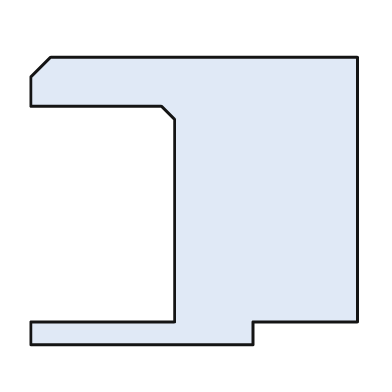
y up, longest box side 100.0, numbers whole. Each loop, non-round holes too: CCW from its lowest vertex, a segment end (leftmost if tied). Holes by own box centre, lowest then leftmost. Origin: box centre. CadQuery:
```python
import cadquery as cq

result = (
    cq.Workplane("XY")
    .moveTo(-50.0, -44.0)
    .lineTo(18.0, -44.0)
    .lineTo(18.0, -37.0)
    .lineTo(50.0, -37.0)
    .lineTo(50.0, 44.0)
    .lineTo(-44.0, 44.0)
    .lineTo(-50.0, 38.0)
    .lineTo(-50.0, 29.0)
    .lineTo(-10.0, 29.0)
    .lineTo(-6.0, 25.0)
    .lineTo(-6.0, -37.0)
    .lineTo(-50.0, -37.0)
    .close()
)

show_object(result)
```